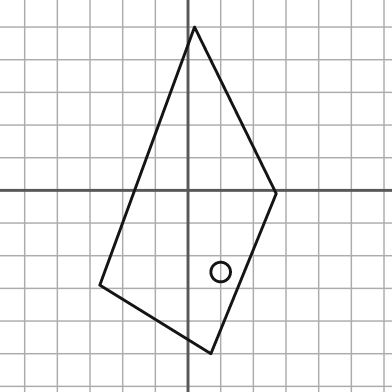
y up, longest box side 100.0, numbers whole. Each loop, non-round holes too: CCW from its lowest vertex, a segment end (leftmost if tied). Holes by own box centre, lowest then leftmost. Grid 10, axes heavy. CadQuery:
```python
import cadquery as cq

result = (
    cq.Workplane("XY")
    .moveTo(7.0, -50.0)
    .lineTo(27.0, -1.0)
    .lineTo(2.0, 50.0)
    .lineTo(-27.0, -29.0)
    .close()
    .moveTo(10.0, -25.0)
    .circle(3.0)
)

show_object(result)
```